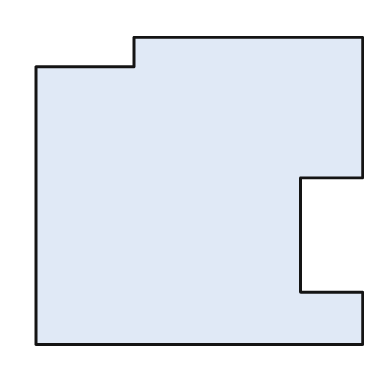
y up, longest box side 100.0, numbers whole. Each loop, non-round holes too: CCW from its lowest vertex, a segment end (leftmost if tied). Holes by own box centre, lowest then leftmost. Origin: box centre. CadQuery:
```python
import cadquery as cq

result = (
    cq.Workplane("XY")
    .moveTo(-50.0, -47.0)
    .lineTo(50.0, -47.0)
    .lineTo(50.0, -31.0)
    .lineTo(31.0, -31.0)
    .lineTo(31.0, 4.0)
    .lineTo(50.0, 4.0)
    .lineTo(50.0, 47.0)
    .lineTo(-20.0, 47.0)
    .lineTo(-20.0, 38.0)
    .lineTo(-50.0, 38.0)
    .close()
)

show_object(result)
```